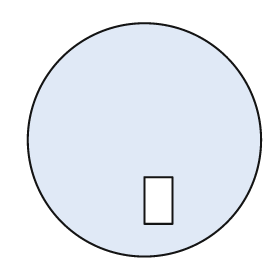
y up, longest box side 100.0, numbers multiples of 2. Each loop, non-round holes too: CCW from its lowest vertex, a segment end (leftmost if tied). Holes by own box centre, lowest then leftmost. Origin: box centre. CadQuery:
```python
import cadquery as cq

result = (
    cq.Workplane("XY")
    .moveTo(0.0, 0.0)
    .circle(50.0)
    .moveTo(0.0, -36.0)
    .lineTo(12.0, -36.0)
    .lineTo(12.0, -16.0)
    .lineTo(0.0, -16.0)
    .close()
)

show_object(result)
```